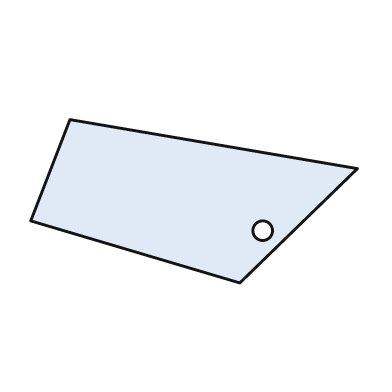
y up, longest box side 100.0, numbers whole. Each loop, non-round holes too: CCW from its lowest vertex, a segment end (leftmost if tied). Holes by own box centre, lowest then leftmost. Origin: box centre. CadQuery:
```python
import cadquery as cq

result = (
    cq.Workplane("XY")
    .moveTo(14.0, -25.0)
    .lineTo(50.0, 10.0)
    .lineTo(-38.0, 25.0)
    .lineTo(-50.0, -6.0)
    .close()
    .moveTo(21.0, -9.0)
    .circle(3.0)
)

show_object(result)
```